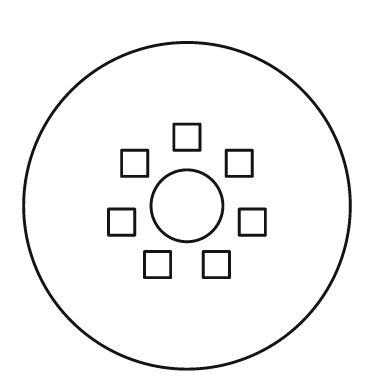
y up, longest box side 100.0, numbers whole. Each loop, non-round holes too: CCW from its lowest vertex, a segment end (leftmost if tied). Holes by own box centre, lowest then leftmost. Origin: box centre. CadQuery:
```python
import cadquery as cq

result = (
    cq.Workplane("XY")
    .moveTo(0.0, 0.0)
    .circle(50.0)
    .moveTo(-13.0, -22.0)
    .lineTo(-5.0, -22.0)
    .lineTo(-5.0, -14.0)
    .lineTo(-13.0, -14.0)
    .close()
    .moveTo(5.0, -22.0)
    .lineTo(13.0, -22.0)
    .lineTo(13.0, -14.0)
    .lineTo(5.0, -14.0)
    .close()
    .moveTo(-24.0, -9.0)
    .lineTo(-16.0, -9.0)
    .lineTo(-16.0, -1.0)
    .lineTo(-24.0, -1.0)
    .close()
    .moveTo(16.0, -9.0)
    .lineTo(24.0, -9.0)
    .lineTo(24.0, -1.0)
    .lineTo(16.0, -1.0)
    .close()
    .moveTo(0.0, 0.0)
    .circle(11.0)
    .moveTo(-20.0, 9.0)
    .lineTo(-12.0, 9.0)
    .lineTo(-12.0, 17.0)
    .lineTo(-20.0, 17.0)
    .close()
    .moveTo(12.0, 9.0)
    .lineTo(20.0, 9.0)
    .lineTo(20.0, 17.0)
    .lineTo(12.0, 17.0)
    .close()
    .moveTo(-4.0, 17.0)
    .lineTo(4.0, 17.0)
    .lineTo(4.0, 25.0)
    .lineTo(-4.0, 25.0)
    .close()
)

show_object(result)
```